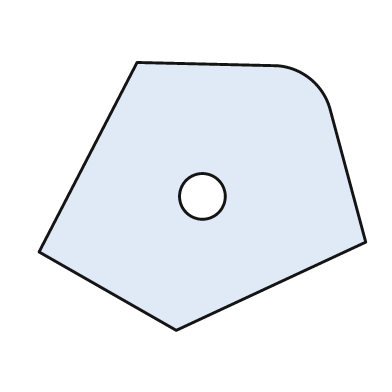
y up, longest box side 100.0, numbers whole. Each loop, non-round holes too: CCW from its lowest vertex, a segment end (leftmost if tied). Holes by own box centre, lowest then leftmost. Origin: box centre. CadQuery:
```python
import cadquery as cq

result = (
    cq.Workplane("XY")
    .moveTo(-8.0, -41.0)
    .lineTo(50.0, -14.0)
    .lineTo(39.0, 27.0)
    .threePointArc((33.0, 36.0), (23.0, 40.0))
    .lineTo(-20.0, 41.0)
    .lineTo(-50.0, -17.0)
    .close()
    .moveTo(0.0, 0.0)
    .circle(7.0)
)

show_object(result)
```